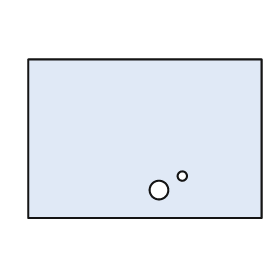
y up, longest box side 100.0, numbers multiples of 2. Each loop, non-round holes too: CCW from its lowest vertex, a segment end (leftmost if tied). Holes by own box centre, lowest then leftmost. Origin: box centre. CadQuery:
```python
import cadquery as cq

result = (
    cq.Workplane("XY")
    .moveTo(-50.0, -34.0)
    .lineTo(50.0, -34.0)
    .lineTo(50.0, 34.0)
    .lineTo(-50.0, 34.0)
    .close()
    .moveTo(6.0, -22.0)
    .circle(4.0)
    .moveTo(16.0, -16.0)
    .circle(2.0)
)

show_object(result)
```